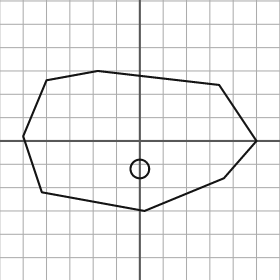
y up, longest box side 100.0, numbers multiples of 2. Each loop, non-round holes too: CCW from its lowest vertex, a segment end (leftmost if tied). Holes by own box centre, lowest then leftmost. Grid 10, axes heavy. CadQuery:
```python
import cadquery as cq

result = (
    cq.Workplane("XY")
    .moveTo(2.0, -30.0)
    .lineTo(36.0, -16.0)
    .lineTo(50.0, 0.0)
    .lineTo(34.0, 24.0)
    .lineTo(-18.0, 30.0)
    .lineTo(-40.0, 26.0)
    .lineTo(-50.0, 2.0)
    .lineTo(-42.0, -22.0)
    .close()
    .moveTo(0.0, -12.0)
    .circle(4.0)
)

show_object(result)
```